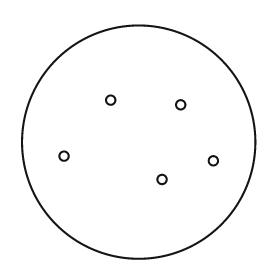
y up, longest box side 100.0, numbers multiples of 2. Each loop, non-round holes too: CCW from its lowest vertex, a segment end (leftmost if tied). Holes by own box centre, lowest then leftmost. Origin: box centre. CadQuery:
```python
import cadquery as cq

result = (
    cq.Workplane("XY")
    .moveTo(0.0, 0.0)
    .circle(50.0)
    .moveTo(10.0, -16.0)
    .circle(2.0)
    .moveTo(32.0, -8.0)
    .circle(2.0)
    .moveTo(-32.0, -6.0)
    .circle(2.0)
    .moveTo(18.0, 16.0)
    .circle(2.0)
    .moveTo(-12.0, 18.0)
    .circle(2.0)
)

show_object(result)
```